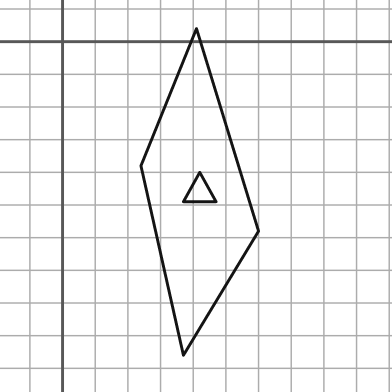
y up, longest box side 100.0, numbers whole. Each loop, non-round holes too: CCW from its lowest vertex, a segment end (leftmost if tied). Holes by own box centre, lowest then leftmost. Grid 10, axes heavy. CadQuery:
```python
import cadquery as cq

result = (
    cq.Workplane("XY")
    .moveTo(37.0, -96.0)
    .lineTo(60.0, -58.0)
    .lineTo(41.0, 4.0)
    .lineTo(24.0, -38.0)
    .close()
    .moveTo(37.0, -49.0)
    .lineTo(47.0, -49.0)
    .lineTo(42.0, -40.0)
    .close()
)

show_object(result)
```